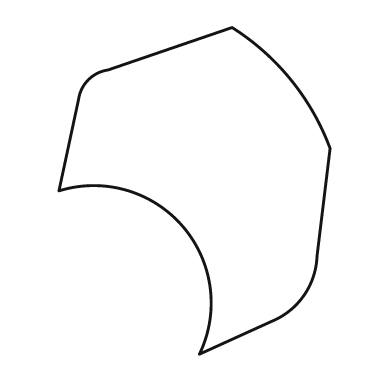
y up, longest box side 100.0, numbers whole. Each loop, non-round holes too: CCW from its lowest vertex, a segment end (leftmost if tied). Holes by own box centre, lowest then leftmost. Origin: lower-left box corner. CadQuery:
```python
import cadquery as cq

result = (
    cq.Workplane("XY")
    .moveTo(43.0, 0.0)
    .lineTo(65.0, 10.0)
    .threePointArc((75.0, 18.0), (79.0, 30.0))
    .lineTo(83.0, 63.0)
    .threePointArc((71.0, 84.0), (53.0, 100.0))
    .lineTo(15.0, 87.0)
    .threePointArc((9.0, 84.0), (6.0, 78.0))
    .lineTo(0.0, 50.0)
    .threePointArc((38.0, 39.0), (43.0, 0.0))
    .close()
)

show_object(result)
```